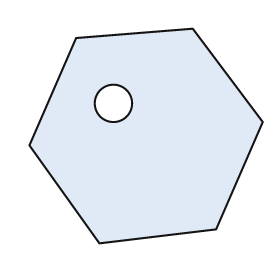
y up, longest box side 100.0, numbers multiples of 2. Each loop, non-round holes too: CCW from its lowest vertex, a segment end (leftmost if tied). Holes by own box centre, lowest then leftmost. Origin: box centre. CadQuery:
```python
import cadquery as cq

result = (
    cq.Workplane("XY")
    .moveTo(-20.0, -46.0)
    .lineTo(30.0, -40.0)
    .lineTo(50.0, 6.0)
    .lineTo(20.0, 46.0)
    .lineTo(-30.0, 42.0)
    .lineTo(-50.0, -4.0)
    .close()
    .moveTo(-14.0, 14.0)
    .circle(8.0)
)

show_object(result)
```